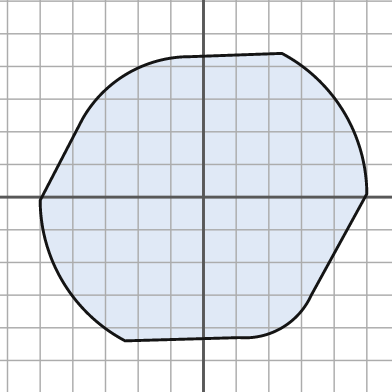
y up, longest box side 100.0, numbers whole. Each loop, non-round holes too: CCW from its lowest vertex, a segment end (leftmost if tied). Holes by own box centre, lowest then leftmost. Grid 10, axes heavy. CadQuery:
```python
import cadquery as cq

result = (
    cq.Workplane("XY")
    .moveTo(-24.0, -44.0)
    .lineTo(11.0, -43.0)
    .threePointArc((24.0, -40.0), (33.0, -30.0))
    .lineTo(50.0, 1.0)
    .threePointArc((43.0, 26.0), (24.0, 44.0))
    .lineTo(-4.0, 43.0)
    .threePointArc((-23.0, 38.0), (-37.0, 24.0))
    .lineTo(-50.0, -1.0)
    .threePointArc((-43.0, -26.0), (-24.0, -44.0))
    .close()
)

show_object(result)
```